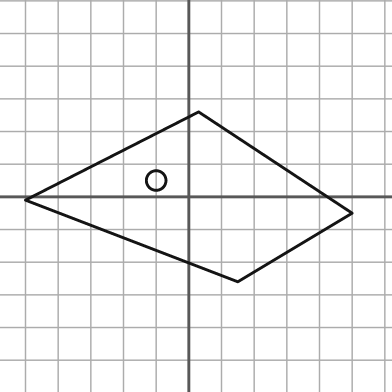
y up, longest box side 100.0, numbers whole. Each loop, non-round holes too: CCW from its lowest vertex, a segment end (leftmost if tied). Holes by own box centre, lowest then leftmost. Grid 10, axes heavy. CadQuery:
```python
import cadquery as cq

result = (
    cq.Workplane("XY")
    .moveTo(15.0, -26.0)
    .lineTo(50.0, -5.0)
    .lineTo(3.0, 26.0)
    .lineTo(-50.0, -1.0)
    .close()
    .moveTo(-10.0, 5.0)
    .circle(3.0)
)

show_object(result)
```